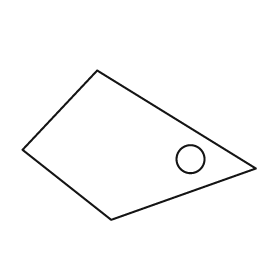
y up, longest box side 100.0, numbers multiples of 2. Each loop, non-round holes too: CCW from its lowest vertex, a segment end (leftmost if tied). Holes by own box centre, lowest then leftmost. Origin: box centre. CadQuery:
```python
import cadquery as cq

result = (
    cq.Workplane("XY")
    .moveTo(-12.0, -32.0)
    .lineTo(50.0, -10.0)
    .lineTo(-18.0, 32.0)
    .lineTo(-50.0, -2.0)
    .close()
    .moveTo(22.0, -6.0)
    .circle(6.0)
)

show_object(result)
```